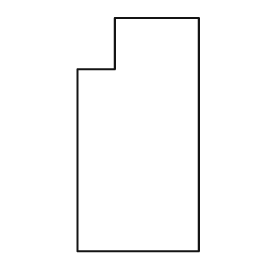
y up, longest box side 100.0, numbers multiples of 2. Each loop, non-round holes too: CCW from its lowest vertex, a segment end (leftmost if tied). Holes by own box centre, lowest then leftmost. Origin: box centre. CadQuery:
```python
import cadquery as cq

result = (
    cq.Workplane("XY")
    .moveTo(-26.0, -50.0)
    .lineTo(26.0, -50.0)
    .lineTo(26.0, 50.0)
    .lineTo(-10.0, 50.0)
    .lineTo(-10.0, 28.0)
    .lineTo(-26.0, 28.0)
    .close()
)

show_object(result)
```